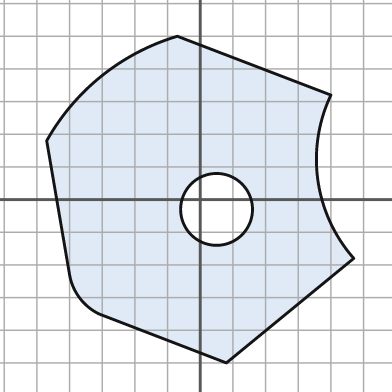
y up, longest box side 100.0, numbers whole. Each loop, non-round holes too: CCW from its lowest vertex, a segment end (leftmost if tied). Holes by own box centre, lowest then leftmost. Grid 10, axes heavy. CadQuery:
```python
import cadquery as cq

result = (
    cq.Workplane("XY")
    .moveTo(8.0, -50.0)
    .lineTo(47.0, -18.0)
    .threePointArc((36.0, 6.0), (40.0, 32.0))
    .lineTo(-7.0, 50.0)
    .threePointArc((-30.0, 38.0), (-47.0, 18.0))
    .lineTo(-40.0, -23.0)
    .threePointArc((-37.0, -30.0), (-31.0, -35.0))
    .close()
    .moveTo(5.0, -3.0)
    .circle(11.0)
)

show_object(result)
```